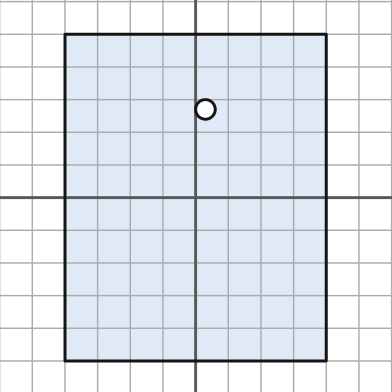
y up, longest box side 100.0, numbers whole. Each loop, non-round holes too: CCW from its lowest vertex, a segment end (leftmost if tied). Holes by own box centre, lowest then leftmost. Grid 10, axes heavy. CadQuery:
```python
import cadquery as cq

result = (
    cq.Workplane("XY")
    .moveTo(-40.0, -50.0)
    .lineTo(40.0, -50.0)
    .lineTo(40.0, 50.0)
    .lineTo(-40.0, 50.0)
    .close()
    .moveTo(3.0, 27.0)
    .circle(3.0)
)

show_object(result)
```